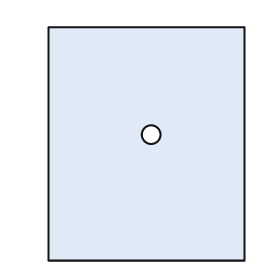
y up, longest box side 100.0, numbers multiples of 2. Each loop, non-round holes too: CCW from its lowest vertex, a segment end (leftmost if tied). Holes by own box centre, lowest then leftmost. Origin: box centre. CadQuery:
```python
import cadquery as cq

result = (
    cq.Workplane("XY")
    .moveTo(-42.0, -50.0)
    .lineTo(42.0, -50.0)
    .lineTo(42.0, 50.0)
    .lineTo(-42.0, 50.0)
    .close()
    .moveTo(2.0, 4.0)
    .circle(4.0)
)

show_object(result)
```